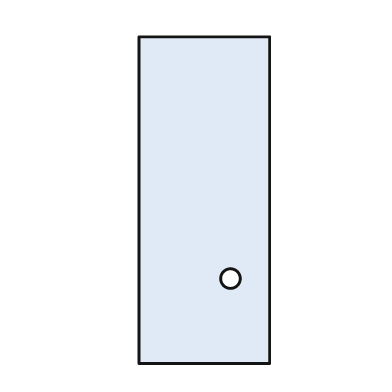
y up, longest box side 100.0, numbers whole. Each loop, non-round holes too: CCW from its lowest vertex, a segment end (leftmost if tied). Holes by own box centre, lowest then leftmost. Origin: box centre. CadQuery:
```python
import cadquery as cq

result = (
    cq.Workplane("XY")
    .moveTo(-20.0, -50.0)
    .lineTo(20.0, -50.0)
    .lineTo(20.0, 50.0)
    .lineTo(-20.0, 50.0)
    .close()
    .moveTo(8.0, -24.0)
    .circle(3.0)
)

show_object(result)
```